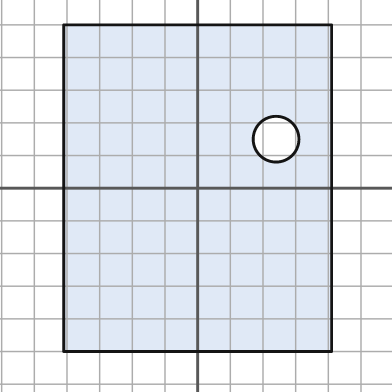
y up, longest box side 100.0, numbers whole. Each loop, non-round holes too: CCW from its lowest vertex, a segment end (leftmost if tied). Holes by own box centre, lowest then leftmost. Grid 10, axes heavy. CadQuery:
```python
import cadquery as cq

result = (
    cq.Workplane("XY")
    .moveTo(-41.0, -50.0)
    .lineTo(41.0, -50.0)
    .lineTo(41.0, 50.0)
    .lineTo(-41.0, 50.0)
    .close()
    .moveTo(24.0, 15.0)
    .circle(7.0)
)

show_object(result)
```